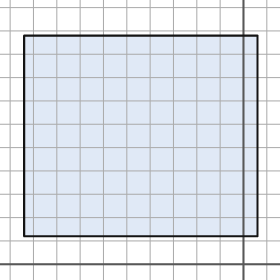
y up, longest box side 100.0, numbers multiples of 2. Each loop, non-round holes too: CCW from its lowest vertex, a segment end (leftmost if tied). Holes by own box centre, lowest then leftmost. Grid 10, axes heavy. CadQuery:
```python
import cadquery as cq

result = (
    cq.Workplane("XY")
    .moveTo(-94.0, 12.0)
    .lineTo(6.0, 12.0)
    .lineTo(6.0, 98.0)
    .lineTo(-94.0, 98.0)
    .close()
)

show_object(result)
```